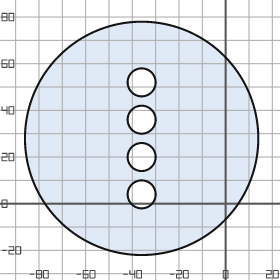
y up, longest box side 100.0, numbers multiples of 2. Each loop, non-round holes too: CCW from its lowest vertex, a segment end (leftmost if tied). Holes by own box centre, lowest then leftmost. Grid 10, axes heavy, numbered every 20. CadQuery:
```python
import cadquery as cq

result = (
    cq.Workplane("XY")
    .moveTo(-36.0, 28.0)
    .circle(50.0)
    .moveTo(-36.0, 4.0)
    .circle(6.0)
    .moveTo(-36.0, 20.0)
    .circle(6.0)
    .moveTo(-36.0, 36.0)
    .circle(6.0)
    .moveTo(-36.0, 52.0)
    .circle(6.0)
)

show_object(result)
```